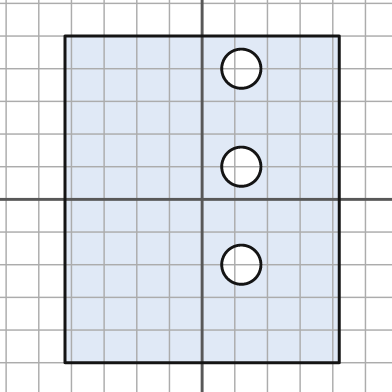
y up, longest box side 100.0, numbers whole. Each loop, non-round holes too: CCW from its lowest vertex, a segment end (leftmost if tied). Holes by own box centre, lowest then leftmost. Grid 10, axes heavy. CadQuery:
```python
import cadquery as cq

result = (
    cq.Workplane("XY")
    .moveTo(-42.0, -50.0)
    .lineTo(42.0, -50.0)
    .lineTo(42.0, 50.0)
    .lineTo(-42.0, 50.0)
    .close()
    .moveTo(12.0, -20.0)
    .circle(6.0)
    .moveTo(12.0, 10.0)
    .circle(6.0)
    .moveTo(12.0, 40.0)
    .circle(6.0)
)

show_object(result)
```